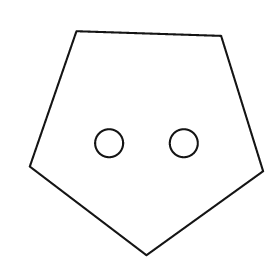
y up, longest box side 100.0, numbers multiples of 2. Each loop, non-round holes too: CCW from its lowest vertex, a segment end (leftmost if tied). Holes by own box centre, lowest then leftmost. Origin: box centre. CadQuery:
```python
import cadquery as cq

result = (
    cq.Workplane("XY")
    .moveTo(0.0, -48.0)
    .lineTo(50.0, -12.0)
    .lineTo(32.0, 46.0)
    .lineTo(-30.0, 48.0)
    .lineTo(-50.0, -10.0)
    .close()
    .moveTo(-16.0, 0.0)
    .circle(6.0)
    .moveTo(16.0, 0.0)
    .circle(6.0)
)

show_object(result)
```